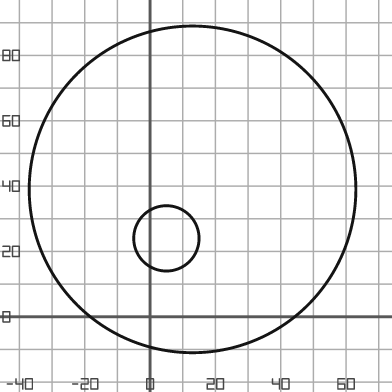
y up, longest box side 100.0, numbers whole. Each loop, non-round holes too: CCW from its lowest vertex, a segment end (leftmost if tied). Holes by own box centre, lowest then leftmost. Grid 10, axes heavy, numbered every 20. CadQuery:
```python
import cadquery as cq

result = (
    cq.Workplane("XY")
    .moveTo(13.0, 39.0)
    .circle(50.0)
    .moveTo(5.0, 24.0)
    .circle(10.0)
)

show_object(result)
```